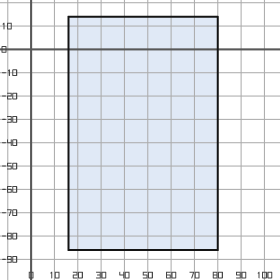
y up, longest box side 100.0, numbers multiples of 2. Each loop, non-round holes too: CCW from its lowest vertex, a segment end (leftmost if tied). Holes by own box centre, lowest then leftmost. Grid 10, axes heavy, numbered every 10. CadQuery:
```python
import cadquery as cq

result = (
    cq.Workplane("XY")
    .moveTo(16.0, -86.0)
    .lineTo(80.0, -86.0)
    .lineTo(80.0, 14.0)
    .lineTo(16.0, 14.0)
    .close()
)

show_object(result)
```